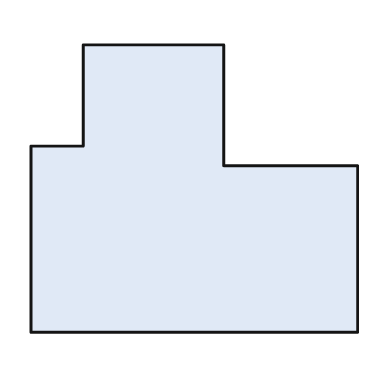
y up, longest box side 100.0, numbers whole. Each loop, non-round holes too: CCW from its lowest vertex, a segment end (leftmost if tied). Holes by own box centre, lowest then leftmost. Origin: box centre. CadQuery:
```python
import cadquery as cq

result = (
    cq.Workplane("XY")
    .moveTo(-50.0, -44.0)
    .lineTo(50.0, -44.0)
    .lineTo(50.0, 7.0)
    .lineTo(9.0, 7.0)
    .lineTo(9.0, 44.0)
    .lineTo(-34.0, 44.0)
    .lineTo(-34.0, 13.0)
    .lineTo(-50.0, 13.0)
    .close()
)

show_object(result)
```